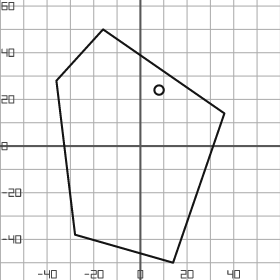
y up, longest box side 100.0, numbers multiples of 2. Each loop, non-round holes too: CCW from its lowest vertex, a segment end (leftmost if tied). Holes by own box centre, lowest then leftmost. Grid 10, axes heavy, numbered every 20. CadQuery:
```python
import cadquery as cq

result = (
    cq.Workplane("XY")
    .moveTo(14.0, -50.0)
    .lineTo(36.0, 14.0)
    .lineTo(-16.0, 50.0)
    .lineTo(-36.0, 28.0)
    .lineTo(-28.0, -38.0)
    .close()
    .moveTo(8.0, 24.0)
    .circle(2.0)
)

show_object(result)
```